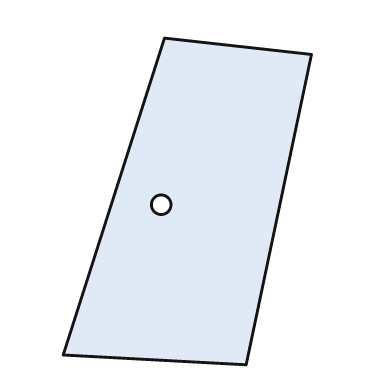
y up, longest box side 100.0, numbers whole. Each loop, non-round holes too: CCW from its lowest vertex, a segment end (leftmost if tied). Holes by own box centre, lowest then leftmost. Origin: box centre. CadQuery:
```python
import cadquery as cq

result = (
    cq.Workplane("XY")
    .moveTo(18.0, -50.0)
    .lineTo(38.0, 45.0)
    .lineTo(-7.0, 50.0)
    .lineTo(-38.0, -47.0)
    .close()
    .moveTo(-8.0, -1.0)
    .circle(3.0)
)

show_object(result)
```